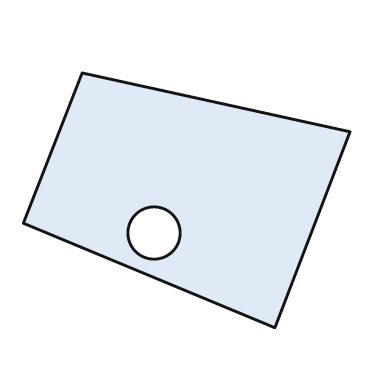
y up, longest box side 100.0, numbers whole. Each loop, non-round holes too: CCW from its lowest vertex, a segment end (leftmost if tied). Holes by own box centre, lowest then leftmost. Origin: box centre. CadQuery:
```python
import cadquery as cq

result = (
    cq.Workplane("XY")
    .moveTo(27.0, -39.0)
    .lineTo(50.0, 21.0)
    .lineTo(-32.0, 39.0)
    .lineTo(-50.0, -7.0)
    .close()
    .moveTo(-10.0, -10.0)
    .circle(8.0)
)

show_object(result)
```